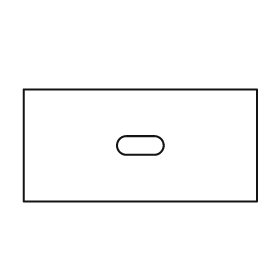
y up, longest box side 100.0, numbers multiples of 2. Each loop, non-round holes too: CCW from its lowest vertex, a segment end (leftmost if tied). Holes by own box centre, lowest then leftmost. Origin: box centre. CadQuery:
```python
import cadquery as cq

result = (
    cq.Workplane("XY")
    .moveTo(-50.0, -24.0)
    .lineTo(50.0, -24.0)
    .lineTo(50.0, 24.0)
    .lineTo(-50.0, 24.0)
    .close()
    .moveTo(-6.0, -4.0)
    .lineTo(6.0, -4.0)
    .threePointArc((10.0, 0.0), (6.0, 4.0))
    .lineTo(-6.0, 4.0)
    .threePointArc((-10.0, 0.0), (-6.0, -4.0))
    .close()
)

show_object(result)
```